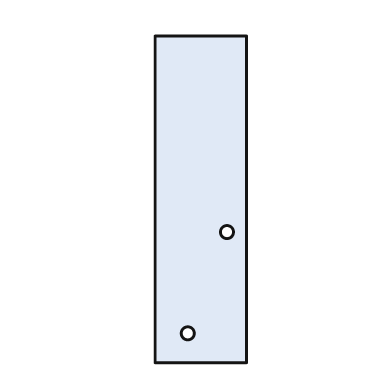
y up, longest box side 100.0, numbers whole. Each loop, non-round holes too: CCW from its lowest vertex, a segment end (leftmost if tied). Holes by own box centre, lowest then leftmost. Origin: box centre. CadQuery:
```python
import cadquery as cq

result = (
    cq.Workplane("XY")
    .moveTo(-14.0, -50.0)
    .lineTo(14.0, -50.0)
    .lineTo(14.0, 50.0)
    .lineTo(-14.0, 50.0)
    .close()
    .moveTo(-4.0, -41.0)
    .circle(2.0)
    .moveTo(8.0, -10.0)
    .circle(2.0)
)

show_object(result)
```